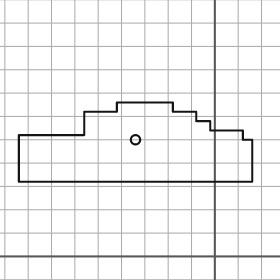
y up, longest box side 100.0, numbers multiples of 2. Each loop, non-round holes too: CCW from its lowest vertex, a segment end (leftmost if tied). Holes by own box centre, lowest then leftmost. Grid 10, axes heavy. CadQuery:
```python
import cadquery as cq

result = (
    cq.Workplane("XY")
    .moveTo(-84.0, 32.0)
    .lineTo(16.0, 32.0)
    .lineTo(16.0, 50.0)
    .lineTo(12.0, 50.0)
    .lineTo(12.0, 54.0)
    .lineTo(-2.0, 54.0)
    .lineTo(-2.0, 58.0)
    .lineTo(-8.0, 58.0)
    .lineTo(-8.0, 62.0)
    .lineTo(-18.0, 62.0)
    .lineTo(-18.0, 66.0)
    .lineTo(-42.0, 66.0)
    .lineTo(-42.0, 62.0)
    .lineTo(-56.0, 62.0)
    .lineTo(-56.0, 52.0)
    .lineTo(-84.0, 52.0)
    .close()
    .moveTo(-34.0, 50.0)
    .circle(2.0)
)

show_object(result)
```